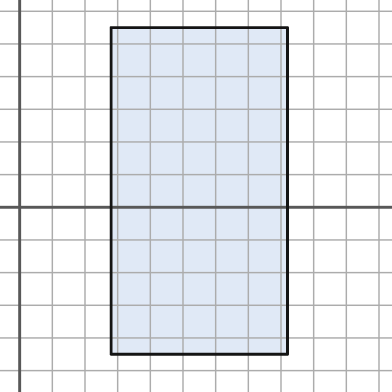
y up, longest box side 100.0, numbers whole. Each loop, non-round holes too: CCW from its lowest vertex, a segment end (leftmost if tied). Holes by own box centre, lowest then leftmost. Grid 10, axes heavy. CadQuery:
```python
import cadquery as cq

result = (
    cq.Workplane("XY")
    .moveTo(28.0, -45.0)
    .lineTo(82.0, -45.0)
    .lineTo(82.0, 55.0)
    .lineTo(28.0, 55.0)
    .close()
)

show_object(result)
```